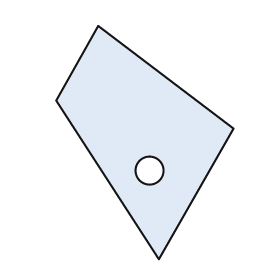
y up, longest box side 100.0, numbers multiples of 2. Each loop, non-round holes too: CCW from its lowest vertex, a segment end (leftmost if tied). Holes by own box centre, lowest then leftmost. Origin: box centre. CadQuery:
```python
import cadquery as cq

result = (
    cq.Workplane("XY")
    .moveTo(6.0, -50.0)
    .lineTo(38.0, 6.0)
    .lineTo(-20.0, 50.0)
    .lineTo(-38.0, 18.0)
    .close()
    .moveTo(2.0, -12.0)
    .circle(6.0)
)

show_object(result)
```